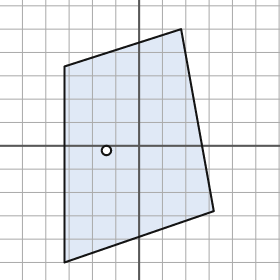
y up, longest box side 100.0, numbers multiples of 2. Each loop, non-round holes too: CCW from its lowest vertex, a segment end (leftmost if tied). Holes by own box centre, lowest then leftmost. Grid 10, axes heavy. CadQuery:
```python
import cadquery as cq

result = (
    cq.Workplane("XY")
    .moveTo(-32.0, -50.0)
    .lineTo(32.0, -28.0)
    .lineTo(18.0, 50.0)
    .lineTo(-32.0, 34.0)
    .close()
    .moveTo(-14.0, -2.0)
    .circle(2.0)
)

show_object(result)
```